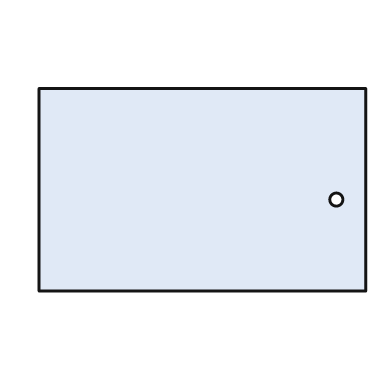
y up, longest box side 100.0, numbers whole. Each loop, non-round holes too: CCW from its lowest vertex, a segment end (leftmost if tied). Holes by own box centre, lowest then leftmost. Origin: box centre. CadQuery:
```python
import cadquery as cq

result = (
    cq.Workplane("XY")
    .moveTo(-50.0, -31.0)
    .lineTo(50.0, -31.0)
    .lineTo(50.0, 31.0)
    .lineTo(-50.0, 31.0)
    .close()
    .moveTo(41.0, -3.0)
    .circle(2.0)
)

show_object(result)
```